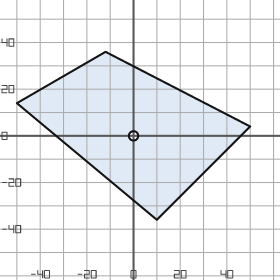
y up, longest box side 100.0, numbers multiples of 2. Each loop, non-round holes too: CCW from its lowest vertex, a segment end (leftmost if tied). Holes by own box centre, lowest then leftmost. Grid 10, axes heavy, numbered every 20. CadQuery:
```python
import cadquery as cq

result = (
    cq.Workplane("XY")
    .moveTo(10.0, -36.0)
    .lineTo(50.0, 4.0)
    .lineTo(-12.0, 36.0)
    .lineTo(-50.0, 14.0)
    .close()
    .moveTo(0.0, 0.0)
    .circle(2.0)
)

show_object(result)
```